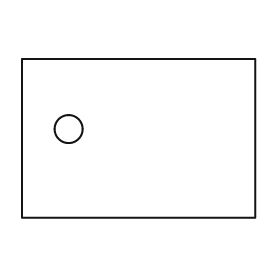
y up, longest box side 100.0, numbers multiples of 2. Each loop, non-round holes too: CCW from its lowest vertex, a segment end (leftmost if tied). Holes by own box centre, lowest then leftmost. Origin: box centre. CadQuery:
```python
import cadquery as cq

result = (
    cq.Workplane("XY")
    .moveTo(-50.0, -34.0)
    .lineTo(50.0, -34.0)
    .lineTo(50.0, 34.0)
    .lineTo(-50.0, 34.0)
    .close()
    .moveTo(-30.0, 4.0)
    .circle(6.0)
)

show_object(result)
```